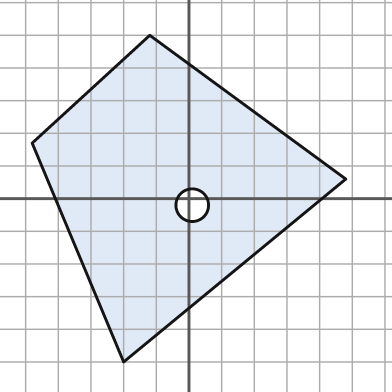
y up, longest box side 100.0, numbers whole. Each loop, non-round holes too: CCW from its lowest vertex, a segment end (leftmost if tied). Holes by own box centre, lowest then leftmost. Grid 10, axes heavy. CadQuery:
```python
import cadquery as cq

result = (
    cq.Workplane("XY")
    .moveTo(-20.0, -50.0)
    .lineTo(48.0, 6.0)
    .lineTo(-12.0, 50.0)
    .lineTo(-48.0, 17.0)
    .close()
    .moveTo(1.0, -2.0)
    .circle(5.0)
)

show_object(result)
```